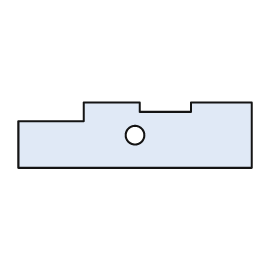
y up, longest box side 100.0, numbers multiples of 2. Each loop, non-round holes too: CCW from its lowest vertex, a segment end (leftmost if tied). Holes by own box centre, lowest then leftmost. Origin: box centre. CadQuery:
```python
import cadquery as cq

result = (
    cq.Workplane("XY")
    .moveTo(-50.0, -14.0)
    .lineTo(50.0, -14.0)
    .lineTo(50.0, 14.0)
    .lineTo(24.0, 14.0)
    .lineTo(24.0, 10.0)
    .lineTo(2.0, 10.0)
    .lineTo(2.0, 14.0)
    .lineTo(-22.0, 14.0)
    .lineTo(-22.0, 6.0)
    .lineTo(-50.0, 6.0)
    .close()
    .moveTo(0.0, 0.0)
    .circle(4.0)
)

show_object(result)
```